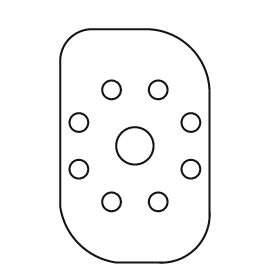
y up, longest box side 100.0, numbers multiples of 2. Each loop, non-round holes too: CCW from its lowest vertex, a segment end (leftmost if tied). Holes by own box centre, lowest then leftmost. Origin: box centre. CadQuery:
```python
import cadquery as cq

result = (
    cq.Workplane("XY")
    .moveTo(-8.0, -50.0)
    .lineTo(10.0, -50.0)
    .threePointArc((26.0, -44.0), (32.0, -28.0))
    .lineTo(32.0, 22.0)
    .threePointArc((24.0, 42.0), (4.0, 50.0))
    .lineTo(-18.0, 50.0)
    .threePointArc((-28.0, 46.0), (-32.0, 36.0))
    .lineTo(-32.0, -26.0)
    .threePointArc((-24.0, -42.0), (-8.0, -50.0))
    .close()
    .moveTo(-10.0, -24.0)
    .circle(4.0)
    .moveTo(10.0, -24.0)
    .circle(4.0)
    .moveTo(-24.0, -10.0)
    .circle(4.0)
    .moveTo(24.0, -10.0)
    .circle(4.0)
    .moveTo(0.0, 0.0)
    .circle(8.0)
    .moveTo(-24.0, 10.0)
    .circle(4.0)
    .moveTo(24.0, 10.0)
    .circle(4.0)
    .moveTo(-10.0, 24.0)
    .circle(4.0)
    .moveTo(10.0, 24.0)
    .circle(4.0)
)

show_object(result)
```